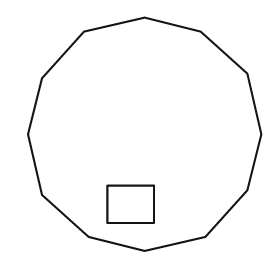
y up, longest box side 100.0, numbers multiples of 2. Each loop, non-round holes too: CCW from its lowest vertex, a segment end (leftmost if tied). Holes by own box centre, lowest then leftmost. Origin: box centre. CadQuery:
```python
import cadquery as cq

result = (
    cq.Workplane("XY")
    .moveTo(0.0, -50.0)
    .lineTo(26.0, -44.0)
    .lineTo(44.0, -24.0)
    .lineTo(50.0, 0.0)
    .lineTo(44.0, 26.0)
    .lineTo(24.0, 44.0)
    .lineTo(0.0, 50.0)
    .lineTo(-26.0, 44.0)
    .lineTo(-44.0, 24.0)
    .lineTo(-50.0, 0.0)
    .lineTo(-44.0, -26.0)
    .lineTo(-24.0, -44.0)
    .close()
    .moveTo(-16.0, -38.0)
    .lineTo(4.0, -38.0)
    .lineTo(4.0, -22.0)
    .lineTo(-16.0, -22.0)
    .close()
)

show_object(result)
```